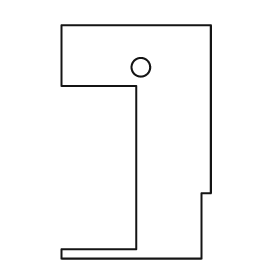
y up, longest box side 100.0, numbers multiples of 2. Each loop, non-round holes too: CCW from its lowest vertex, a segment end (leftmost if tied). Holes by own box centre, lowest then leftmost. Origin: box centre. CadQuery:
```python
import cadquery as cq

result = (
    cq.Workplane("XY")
    .moveTo(-32.0, -50.0)
    .lineTo(28.0, -50.0)
    .lineTo(28.0, -22.0)
    .lineTo(32.0, -22.0)
    .lineTo(32.0, 50.0)
    .lineTo(-32.0, 50.0)
    .lineTo(-32.0, 24.0)
    .lineTo(0.0, 24.0)
    .lineTo(0.0, -46.0)
    .lineTo(-32.0, -46.0)
    .close()
    .moveTo(2.0, 32.0)
    .circle(4.0)
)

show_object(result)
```